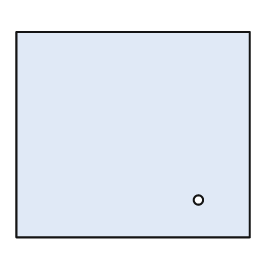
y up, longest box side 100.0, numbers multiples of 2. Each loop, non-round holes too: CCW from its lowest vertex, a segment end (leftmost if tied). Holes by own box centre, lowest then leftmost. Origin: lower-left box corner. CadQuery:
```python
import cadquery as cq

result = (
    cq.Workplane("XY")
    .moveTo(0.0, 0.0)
    .lineTo(100.0, 0.0)
    .lineTo(100.0, 88.0)
    .lineTo(0.0, 88.0)
    .close()
    .moveTo(78.0, 16.0)
    .circle(2.0)
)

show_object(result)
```